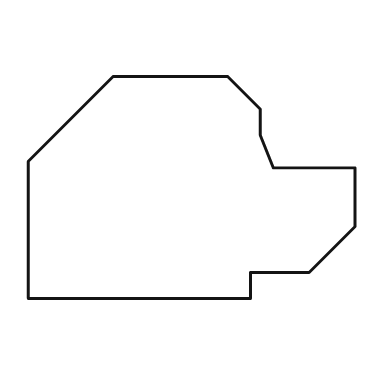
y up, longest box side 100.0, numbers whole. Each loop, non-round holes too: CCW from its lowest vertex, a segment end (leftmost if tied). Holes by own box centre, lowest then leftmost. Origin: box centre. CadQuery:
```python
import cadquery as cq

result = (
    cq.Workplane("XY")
    .moveTo(-50.0, -34.0)
    .lineTo(18.0, -34.0)
    .lineTo(18.0, -26.0)
    .lineTo(36.0, -26.0)
    .lineTo(50.0, -12.0)
    .lineTo(50.0, 6.0)
    .lineTo(25.0, 6.0)
    .lineTo(21.0, 16.0)
    .lineTo(21.0, 24.0)
    .lineTo(11.0, 34.0)
    .lineTo(-24.0, 34.0)
    .lineTo(-50.0, 8.0)
    .close()
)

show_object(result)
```